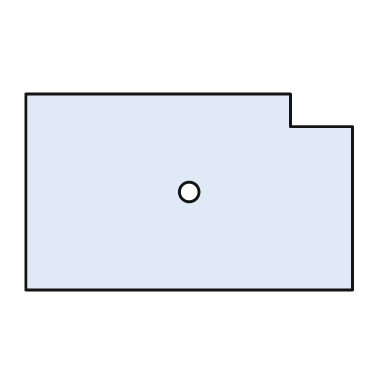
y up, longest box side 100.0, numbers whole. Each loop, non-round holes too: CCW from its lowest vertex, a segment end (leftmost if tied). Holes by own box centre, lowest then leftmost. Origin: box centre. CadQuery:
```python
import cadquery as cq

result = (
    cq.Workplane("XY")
    .moveTo(-50.0, -30.0)
    .lineTo(50.0, -30.0)
    .lineTo(50.0, 20.0)
    .lineTo(31.0, 20.0)
    .lineTo(31.0, 30.0)
    .lineTo(-50.0, 30.0)
    .close()
    .moveTo(0.0, 0.0)
    .circle(3.0)
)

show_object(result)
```